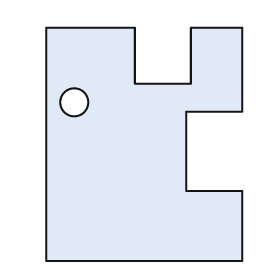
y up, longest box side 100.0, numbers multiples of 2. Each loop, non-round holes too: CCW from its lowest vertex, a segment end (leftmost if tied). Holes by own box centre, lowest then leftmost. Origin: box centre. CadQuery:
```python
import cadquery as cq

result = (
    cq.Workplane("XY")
    .moveTo(-42.0, -50.0)
    .lineTo(42.0, -50.0)
    .lineTo(42.0, -20.0)
    .lineTo(18.0, -20.0)
    .lineTo(18.0, 14.0)
    .lineTo(42.0, 14.0)
    .lineTo(42.0, 50.0)
    .lineTo(20.0, 50.0)
    .lineTo(20.0, 26.0)
    .lineTo(-4.0, 26.0)
    .lineTo(-4.0, 50.0)
    .lineTo(-42.0, 50.0)
    .close()
    .moveTo(-30.0, 18.0)
    .circle(6.0)
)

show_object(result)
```